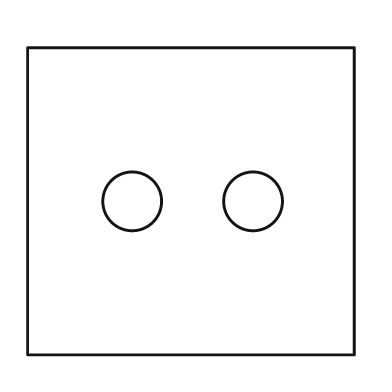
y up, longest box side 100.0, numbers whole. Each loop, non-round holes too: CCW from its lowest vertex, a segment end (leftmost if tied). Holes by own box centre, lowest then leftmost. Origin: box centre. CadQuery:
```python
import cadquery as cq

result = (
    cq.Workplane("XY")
    .moveTo(-50.0, -47.0)
    .lineTo(50.0, -47.0)
    .lineTo(50.0, 47.0)
    .lineTo(-50.0, 47.0)
    .close()
    .moveTo(-18.0, 0.0)
    .circle(9.0)
    .moveTo(19.0, 0.0)
    .circle(9.0)
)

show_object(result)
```